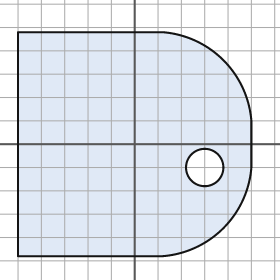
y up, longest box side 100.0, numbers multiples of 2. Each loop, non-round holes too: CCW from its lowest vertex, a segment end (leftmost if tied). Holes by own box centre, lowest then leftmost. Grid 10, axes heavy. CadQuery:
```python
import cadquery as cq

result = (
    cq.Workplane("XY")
    .moveTo(-50.0, -48.0)
    .lineTo(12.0, -48.0)
    .threePointArc((38.0, -36.0), (50.0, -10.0))
    .lineTo(50.0, 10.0)
    .threePointArc((38.0, 36.0), (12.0, 48.0))
    .lineTo(-50.0, 48.0)
    .close()
    .moveTo(30.0, -10.0)
    .circle(8.0)
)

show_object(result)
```